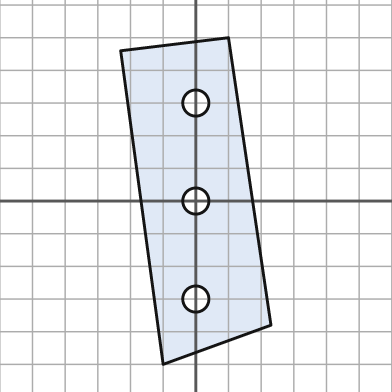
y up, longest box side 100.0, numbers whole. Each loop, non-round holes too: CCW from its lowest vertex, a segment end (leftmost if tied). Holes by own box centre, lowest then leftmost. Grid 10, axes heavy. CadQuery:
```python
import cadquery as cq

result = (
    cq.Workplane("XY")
    .moveTo(-10.0, -50.0)
    .lineTo(23.0, -38.0)
    .lineTo(10.0, 50.0)
    .lineTo(-23.0, 46.0)
    .close()
    .moveTo(0.0, -30.0)
    .circle(4.0)
    .moveTo(0.0, 0.0)
    .circle(4.0)
    .moveTo(0.0, 30.0)
    .circle(4.0)
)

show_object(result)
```